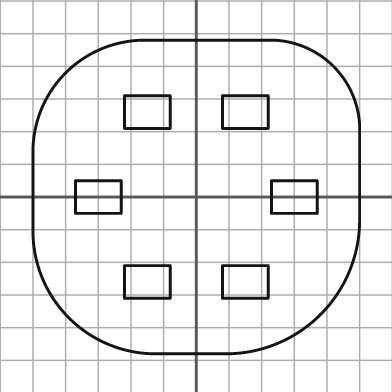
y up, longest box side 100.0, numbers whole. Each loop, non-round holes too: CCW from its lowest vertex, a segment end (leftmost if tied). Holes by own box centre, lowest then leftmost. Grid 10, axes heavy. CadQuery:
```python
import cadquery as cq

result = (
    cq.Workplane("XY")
    .moveTo(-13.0, -48.0)
    .lineTo(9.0, -48.0)
    .threePointArc((38.0, -36.0), (50.0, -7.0))
    .lineTo(50.0, 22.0)
    .threePointArc((42.0, 40.0), (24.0, 48.0))
    .lineTo(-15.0, 48.0)
    .threePointArc((-40.0, 38.0), (-50.0, 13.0))
    .lineTo(-50.0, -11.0)
    .threePointArc((-39.0, -37.0), (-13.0, -48.0))
    .close()
    .moveTo(-22.0, -31.0)
    .lineTo(-8.0, -31.0)
    .lineTo(-8.0, -21.0)
    .lineTo(-22.0, -21.0)
    .close()
    .moveTo(8.0, -31.0)
    .lineTo(22.0, -31.0)
    .lineTo(22.0, -21.0)
    .lineTo(8.0, -21.0)
    .close()
    .moveTo(-37.0, -5.0)
    .lineTo(-23.0, -5.0)
    .lineTo(-23.0, 5.0)
    .lineTo(-37.0, 5.0)
    .close()
    .moveTo(23.0, -5.0)
    .lineTo(37.0, -5.0)
    .lineTo(37.0, 5.0)
    .lineTo(23.0, 5.0)
    .close()
    .moveTo(-22.0, 21.0)
    .lineTo(-8.0, 21.0)
    .lineTo(-8.0, 31.0)
    .lineTo(-22.0, 31.0)
    .close()
    .moveTo(8.0, 21.0)
    .lineTo(22.0, 21.0)
    .lineTo(22.0, 31.0)
    .lineTo(8.0, 31.0)
    .close()
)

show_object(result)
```